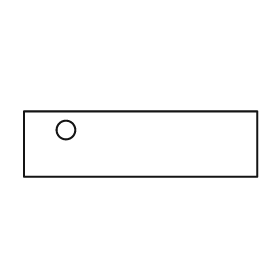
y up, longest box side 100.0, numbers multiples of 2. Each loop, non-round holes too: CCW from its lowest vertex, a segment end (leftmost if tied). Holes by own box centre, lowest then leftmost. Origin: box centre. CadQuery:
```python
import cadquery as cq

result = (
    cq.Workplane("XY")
    .moveTo(-50.0, -14.0)
    .lineTo(50.0, -14.0)
    .lineTo(50.0, 14.0)
    .lineTo(-50.0, 14.0)
    .close()
    .moveTo(-32.0, 6.0)
    .circle(4.0)
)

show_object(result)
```